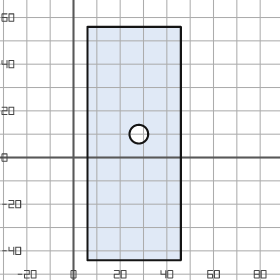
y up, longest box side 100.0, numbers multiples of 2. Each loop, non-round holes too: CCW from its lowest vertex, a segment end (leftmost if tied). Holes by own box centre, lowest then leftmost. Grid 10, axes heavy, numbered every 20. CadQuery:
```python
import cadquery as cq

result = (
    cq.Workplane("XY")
    .moveTo(6.0, -44.0)
    .lineTo(46.0, -44.0)
    .lineTo(46.0, 56.0)
    .lineTo(6.0, 56.0)
    .close()
    .moveTo(28.0, 10.0)
    .circle(4.0)
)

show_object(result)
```